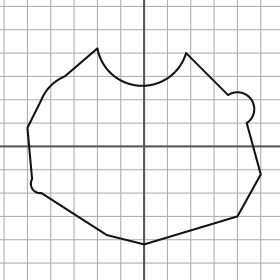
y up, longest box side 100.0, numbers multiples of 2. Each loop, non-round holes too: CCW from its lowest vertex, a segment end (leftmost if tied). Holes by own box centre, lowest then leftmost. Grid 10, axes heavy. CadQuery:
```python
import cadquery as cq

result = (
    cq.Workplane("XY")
    .moveTo(0.0, -42.0)
    .lineTo(40.0, -30.0)
    .lineTo(50.0, -12.0)
    .lineTo(44.0, 10.0)
    .threePointArc((46.0, 20.0), (36.0, 22.0))
    .lineTo(18.0, 40.0)
    .threePointArc((-2.0, 26.0), (-20.0, 42.0))
    .lineTo(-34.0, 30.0)
    .threePointArc((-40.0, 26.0), (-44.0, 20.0))
    .lineTo(-50.0, 8.0)
    .lineTo(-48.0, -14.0)
    .threePointArc((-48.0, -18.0), (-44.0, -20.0))
    .lineTo(-16.0, -38.0)
    .close()
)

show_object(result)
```